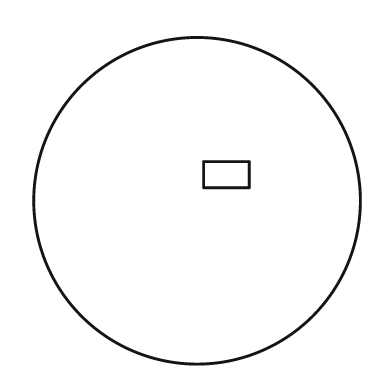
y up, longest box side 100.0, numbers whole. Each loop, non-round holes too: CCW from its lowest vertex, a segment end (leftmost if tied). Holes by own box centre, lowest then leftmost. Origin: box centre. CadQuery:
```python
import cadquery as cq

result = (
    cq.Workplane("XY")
    .moveTo(0.0, 0.0)
    .circle(50.0)
    .moveTo(2.0, 4.0)
    .lineTo(16.0, 4.0)
    .lineTo(16.0, 12.0)
    .lineTo(2.0, 12.0)
    .close()
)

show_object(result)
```